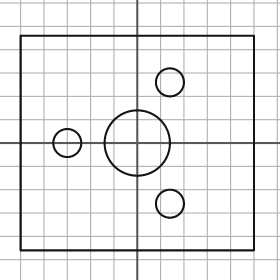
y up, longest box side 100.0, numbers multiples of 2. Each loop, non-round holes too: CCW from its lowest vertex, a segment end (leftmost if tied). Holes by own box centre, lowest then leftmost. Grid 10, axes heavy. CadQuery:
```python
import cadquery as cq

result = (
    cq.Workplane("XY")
    .moveTo(-50.0, -46.0)
    .lineTo(50.0, -46.0)
    .lineTo(50.0, 46.0)
    .lineTo(-50.0, 46.0)
    .close()
    .moveTo(14.0, -26.0)
    .circle(6.0)
    .moveTo(-30.0, 0.0)
    .circle(6.0)
    .moveTo(0.0, 0.0)
    .circle(14.0)
    .moveTo(14.0, 26.0)
    .circle(6.0)
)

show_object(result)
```